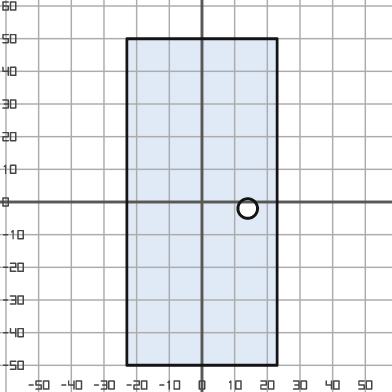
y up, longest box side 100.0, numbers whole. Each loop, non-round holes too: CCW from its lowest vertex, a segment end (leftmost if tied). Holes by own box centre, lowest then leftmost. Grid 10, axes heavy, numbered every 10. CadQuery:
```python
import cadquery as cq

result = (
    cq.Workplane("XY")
    .moveTo(-23.0, -50.0)
    .lineTo(23.0, -50.0)
    .lineTo(23.0, 50.0)
    .lineTo(-23.0, 50.0)
    .close()
    .moveTo(14.0, -2.0)
    .circle(3.0)
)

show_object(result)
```